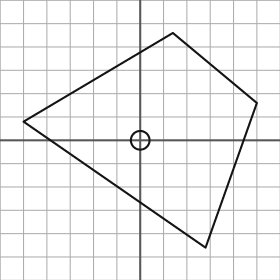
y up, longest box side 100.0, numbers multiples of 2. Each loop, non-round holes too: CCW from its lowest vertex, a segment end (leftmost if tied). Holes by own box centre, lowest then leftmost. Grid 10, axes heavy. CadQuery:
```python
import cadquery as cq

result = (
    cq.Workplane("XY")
    .moveTo(28.0, -46.0)
    .lineTo(50.0, 16.0)
    .lineTo(14.0, 46.0)
    .lineTo(-50.0, 8.0)
    .close()
    .moveTo(0.0, 0.0)
    .circle(4.0)
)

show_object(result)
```